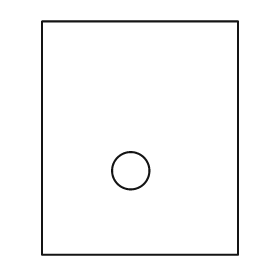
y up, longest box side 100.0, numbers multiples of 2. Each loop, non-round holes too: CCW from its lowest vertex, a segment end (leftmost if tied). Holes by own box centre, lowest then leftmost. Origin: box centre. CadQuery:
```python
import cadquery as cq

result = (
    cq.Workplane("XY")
    .moveTo(-42.0, -50.0)
    .lineTo(42.0, -50.0)
    .lineTo(42.0, 50.0)
    .lineTo(-42.0, 50.0)
    .close()
    .moveTo(-4.0, -14.0)
    .circle(8.0)
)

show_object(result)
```